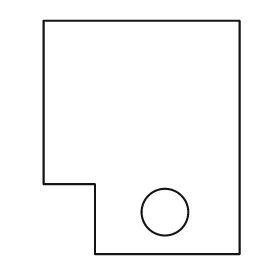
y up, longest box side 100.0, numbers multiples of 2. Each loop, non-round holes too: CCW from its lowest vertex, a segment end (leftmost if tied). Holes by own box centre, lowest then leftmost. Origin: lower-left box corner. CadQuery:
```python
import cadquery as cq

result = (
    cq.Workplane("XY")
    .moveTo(22.0, 0.0)
    .lineTo(84.0, 0.0)
    .lineTo(84.0, 100.0)
    .lineTo(0.0, 100.0)
    .lineTo(0.0, 30.0)
    .lineTo(22.0, 30.0)
    .close()
    .moveTo(52.0, 18.0)
    .circle(10.0)
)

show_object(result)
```